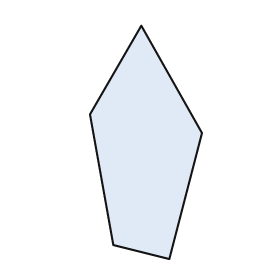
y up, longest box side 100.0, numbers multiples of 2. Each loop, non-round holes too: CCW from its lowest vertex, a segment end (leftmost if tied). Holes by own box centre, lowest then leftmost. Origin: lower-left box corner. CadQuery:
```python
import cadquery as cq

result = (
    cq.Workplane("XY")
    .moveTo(34.0, 0.0)
    .lineTo(48.0, 54.0)
    .lineTo(22.0, 100.0)
    .lineTo(0.0, 62.0)
    .lineTo(10.0, 6.0)
    .close()
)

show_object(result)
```